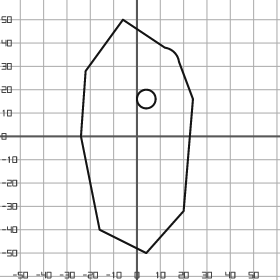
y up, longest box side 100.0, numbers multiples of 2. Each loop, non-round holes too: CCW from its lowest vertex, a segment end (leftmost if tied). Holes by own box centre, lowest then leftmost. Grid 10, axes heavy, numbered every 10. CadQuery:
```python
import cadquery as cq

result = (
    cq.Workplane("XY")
    .moveTo(4.0, -50.0)
    .lineTo(20.0, -32.0)
    .lineTo(24.0, 16.0)
    .lineTo(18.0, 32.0)
    .threePointArc((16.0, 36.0), (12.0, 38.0))
    .lineTo(-6.0, 50.0)
    .lineTo(-22.0, 28.0)
    .lineTo(-24.0, 0.0)
    .lineTo(-16.0, -40.0)
    .close()
    .moveTo(4.0, 16.0)
    .circle(4.0)
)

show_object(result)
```